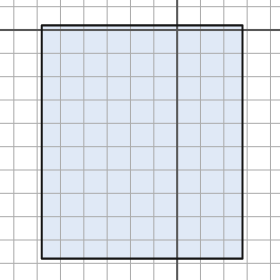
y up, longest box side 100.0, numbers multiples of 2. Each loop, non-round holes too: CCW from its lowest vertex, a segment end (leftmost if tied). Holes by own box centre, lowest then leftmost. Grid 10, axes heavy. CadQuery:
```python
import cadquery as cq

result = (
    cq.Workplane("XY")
    .moveTo(-58.0, -98.0)
    .lineTo(28.0, -98.0)
    .lineTo(28.0, 2.0)
    .lineTo(-58.0, 2.0)
    .close()
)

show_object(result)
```